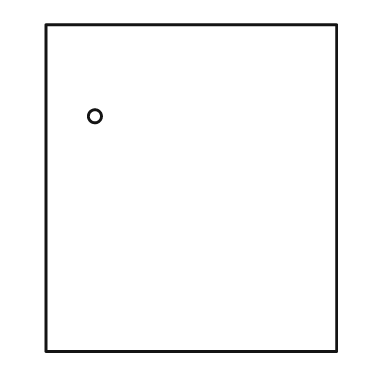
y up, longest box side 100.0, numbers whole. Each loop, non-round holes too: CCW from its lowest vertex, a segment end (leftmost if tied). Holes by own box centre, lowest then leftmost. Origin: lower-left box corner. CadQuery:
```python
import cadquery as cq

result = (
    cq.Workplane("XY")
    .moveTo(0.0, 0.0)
    .lineTo(89.0, 0.0)
    .lineTo(89.0, 100.0)
    .lineTo(0.0, 100.0)
    .close()
    .moveTo(15.0, 72.0)
    .circle(2.0)
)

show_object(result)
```